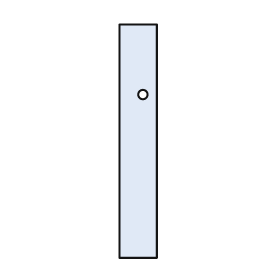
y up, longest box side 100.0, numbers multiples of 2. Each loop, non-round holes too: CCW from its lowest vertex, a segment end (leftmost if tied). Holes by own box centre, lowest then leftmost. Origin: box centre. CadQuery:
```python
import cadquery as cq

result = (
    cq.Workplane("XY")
    .moveTo(-8.0, -50.0)
    .lineTo(8.0, -50.0)
    .lineTo(8.0, 50.0)
    .lineTo(-8.0, 50.0)
    .close()
    .moveTo(2.0, 20.0)
    .circle(2.0)
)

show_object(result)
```